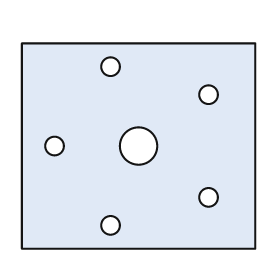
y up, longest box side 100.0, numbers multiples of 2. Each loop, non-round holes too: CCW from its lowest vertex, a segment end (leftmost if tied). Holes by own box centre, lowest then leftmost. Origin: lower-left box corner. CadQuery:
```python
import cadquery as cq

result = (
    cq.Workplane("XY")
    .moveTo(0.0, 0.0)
    .lineTo(100.0, 0.0)
    .lineTo(100.0, 88.0)
    .lineTo(0.0, 88.0)
    .close()
    .moveTo(38.0, 10.0)
    .circle(4.0)
    .moveTo(80.0, 22.0)
    .circle(4.0)
    .moveTo(14.0, 44.0)
    .circle(4.0)
    .moveTo(50.0, 44.0)
    .circle(8.0)
    .moveTo(80.0, 66.0)
    .circle(4.0)
    .moveTo(38.0, 78.0)
    .circle(4.0)
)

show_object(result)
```